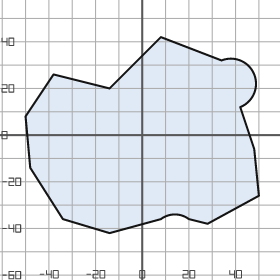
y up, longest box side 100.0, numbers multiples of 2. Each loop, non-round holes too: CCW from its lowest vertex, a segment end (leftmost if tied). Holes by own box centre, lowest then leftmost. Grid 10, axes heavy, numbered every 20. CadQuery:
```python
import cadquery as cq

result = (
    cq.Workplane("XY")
    .moveTo(-14.0, -42.0)
    .lineTo(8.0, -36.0)
    .threePointArc((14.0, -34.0), (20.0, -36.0))
    .lineTo(28.0, -38.0)
    .lineTo(50.0, -26.0)
    .lineTo(48.0, -6.0)
    .lineTo(42.0, 12.0)
    .threePointArc((48.0, 26.0), (34.0, 32.0))
    .lineTo(8.0, 42.0)
    .lineTo(-14.0, 20.0)
    .lineTo(-38.0, 26.0)
    .lineTo(-50.0, 8.0)
    .lineTo(-48.0, -14.0)
    .lineTo(-34.0, -36.0)
    .close()
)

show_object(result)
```